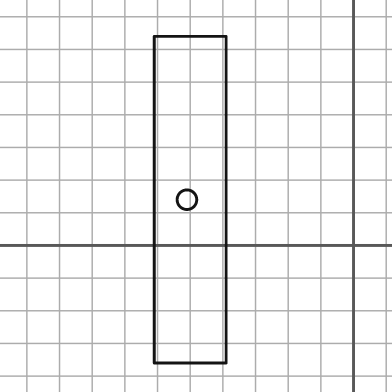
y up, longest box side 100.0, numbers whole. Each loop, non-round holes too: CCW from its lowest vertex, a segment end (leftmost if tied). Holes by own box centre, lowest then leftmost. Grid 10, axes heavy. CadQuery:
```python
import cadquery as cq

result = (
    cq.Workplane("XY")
    .moveTo(-61.0, -36.0)
    .lineTo(-39.0, -36.0)
    .lineTo(-39.0, 64.0)
    .lineTo(-61.0, 64.0)
    .close()
    .moveTo(-51.0, 14.0)
    .circle(3.0)
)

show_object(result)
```